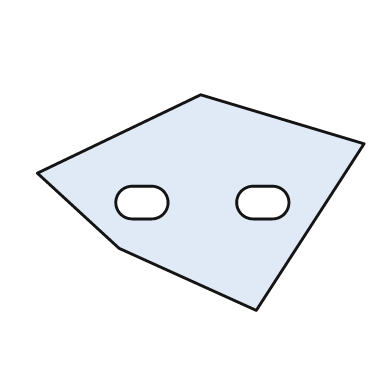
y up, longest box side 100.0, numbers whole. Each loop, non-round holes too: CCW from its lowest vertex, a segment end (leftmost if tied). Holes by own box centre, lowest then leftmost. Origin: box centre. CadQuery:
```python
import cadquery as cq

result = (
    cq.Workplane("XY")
    .moveTo(17.0, -33.0)
    .lineTo(50.0, 18.0)
    .lineTo(0.0, 33.0)
    .lineTo(-50.0, 9.0)
    .lineTo(-25.0, -14.0)
    .close()
    .moveTo(-21.0, -5.0)
    .lineTo(-15.0, -5.0)
    .threePointArc((-10.0, 0.0), (-15.0, 5.0))
    .lineTo(-21.0, 5.0)
    .threePointArc((-26.0, 0.0), (-21.0, -5.0))
    .close()
    .moveTo(16.0, -5.0)
    .lineTo(22.0, -5.0)
    .threePointArc((27.0, 0.0), (22.0, 5.0))
    .lineTo(16.0, 5.0)
    .threePointArc((11.0, 0.0), (16.0, -5.0))
    .close()
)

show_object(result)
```